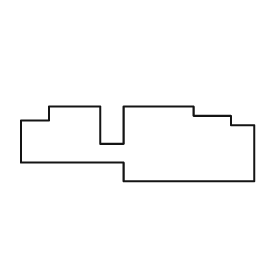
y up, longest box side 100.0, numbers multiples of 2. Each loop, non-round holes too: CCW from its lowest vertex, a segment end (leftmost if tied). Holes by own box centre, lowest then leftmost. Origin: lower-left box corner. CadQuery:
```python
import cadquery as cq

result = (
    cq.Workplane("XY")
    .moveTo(44.0, 0.0)
    .lineTo(100.0, 0.0)
    .lineTo(100.0, 24.0)
    .lineTo(90.0, 24.0)
    .lineTo(90.0, 28.0)
    .lineTo(74.0, 28.0)
    .lineTo(74.0, 32.0)
    .lineTo(44.0, 32.0)
    .lineTo(44.0, 16.0)
    .lineTo(34.0, 16.0)
    .lineTo(34.0, 32.0)
    .lineTo(12.0, 32.0)
    .lineTo(12.0, 26.0)
    .lineTo(0.0, 26.0)
    .lineTo(0.0, 8.0)
    .lineTo(44.0, 8.0)
    .close()
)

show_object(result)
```